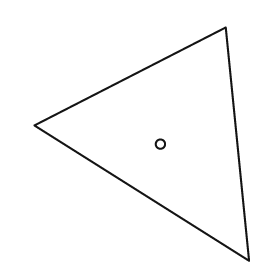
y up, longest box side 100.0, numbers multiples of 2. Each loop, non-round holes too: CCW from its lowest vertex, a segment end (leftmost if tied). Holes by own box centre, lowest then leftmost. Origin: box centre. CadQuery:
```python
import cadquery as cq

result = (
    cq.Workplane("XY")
    .moveTo(46.0, -50.0)
    .lineTo(36.0, 50.0)
    .lineTo(-46.0, 8.0)
    .close()
    .moveTo(8.0, 0.0)
    .circle(2.0)
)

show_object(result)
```